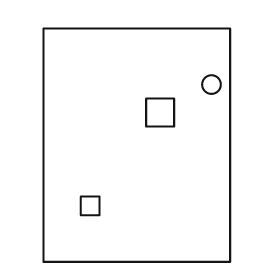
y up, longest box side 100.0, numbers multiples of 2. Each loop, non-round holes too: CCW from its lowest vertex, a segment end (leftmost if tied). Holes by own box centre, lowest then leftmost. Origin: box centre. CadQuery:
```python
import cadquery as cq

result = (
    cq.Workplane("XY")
    .moveTo(-40.0, -50.0)
    .lineTo(40.0, -50.0)
    .lineTo(40.0, 50.0)
    .lineTo(-40.0, 50.0)
    .close()
    .moveTo(-24.0, -30.0)
    .lineTo(-16.0, -30.0)
    .lineTo(-16.0, -22.0)
    .lineTo(-24.0, -22.0)
    .close()
    .moveTo(4.0, 8.0)
    .lineTo(16.0, 8.0)
    .lineTo(16.0, 20.0)
    .lineTo(4.0, 20.0)
    .close()
    .moveTo(32.0, 26.0)
    .circle(4.0)
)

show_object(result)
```